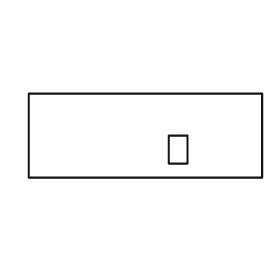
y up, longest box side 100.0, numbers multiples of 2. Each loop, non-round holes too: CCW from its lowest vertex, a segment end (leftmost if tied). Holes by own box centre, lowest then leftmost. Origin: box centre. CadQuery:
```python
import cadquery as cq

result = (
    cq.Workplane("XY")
    .moveTo(-50.0, -18.0)
    .lineTo(50.0, -18.0)
    .lineTo(50.0, 18.0)
    .lineTo(-50.0, 18.0)
    .close()
    .moveTo(10.0, -12.0)
    .lineTo(18.0, -12.0)
    .lineTo(18.0, 0.0)
    .lineTo(10.0, 0.0)
    .close()
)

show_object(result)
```